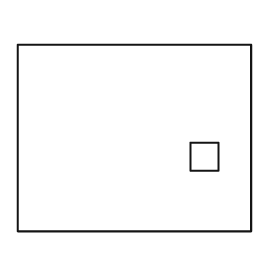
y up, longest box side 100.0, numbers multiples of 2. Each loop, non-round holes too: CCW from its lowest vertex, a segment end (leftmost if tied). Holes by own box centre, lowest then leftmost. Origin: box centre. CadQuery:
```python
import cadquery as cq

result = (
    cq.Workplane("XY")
    .moveTo(-50.0, -40.0)
    .lineTo(50.0, -40.0)
    .lineTo(50.0, 40.0)
    .lineTo(-50.0, 40.0)
    .close()
    .moveTo(24.0, -14.0)
    .lineTo(36.0, -14.0)
    .lineTo(36.0, -2.0)
    .lineTo(24.0, -2.0)
    .close()
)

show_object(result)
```